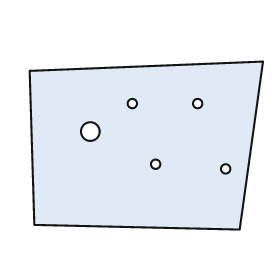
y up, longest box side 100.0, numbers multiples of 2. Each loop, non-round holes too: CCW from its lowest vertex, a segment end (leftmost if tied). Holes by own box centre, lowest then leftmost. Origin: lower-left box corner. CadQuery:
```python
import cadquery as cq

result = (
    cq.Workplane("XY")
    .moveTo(90.0, 0.0)
    .lineTo(100.0, 72.0)
    .lineTo(0.0, 68.0)
    .lineTo(2.0, 2.0)
    .close()
    .moveTo(84.0, 26.0)
    .circle(2.0)
    .moveTo(54.0, 28.0)
    .circle(2.0)
    .moveTo(26.0, 42.0)
    .circle(4.0)
    .moveTo(44.0, 54.0)
    .circle(2.0)
    .moveTo(72.0, 54.0)
    .circle(2.0)
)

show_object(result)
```